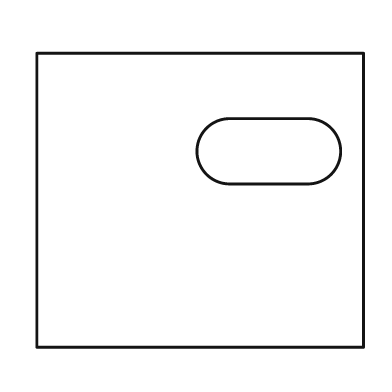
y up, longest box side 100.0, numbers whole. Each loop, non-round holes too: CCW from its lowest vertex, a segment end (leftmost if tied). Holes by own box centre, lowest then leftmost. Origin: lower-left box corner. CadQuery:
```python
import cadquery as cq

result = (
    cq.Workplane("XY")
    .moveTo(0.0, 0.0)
    .lineTo(100.0, 0.0)
    .lineTo(100.0, 90.0)
    .lineTo(0.0, 90.0)
    .close()
    .moveTo(59.0, 50.0)
    .lineTo(83.0, 50.0)
    .threePointArc((93.0, 60.0), (83.0, 70.0))
    .lineTo(59.0, 70.0)
    .threePointArc((49.0, 60.0), (59.0, 50.0))
    .close()
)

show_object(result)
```